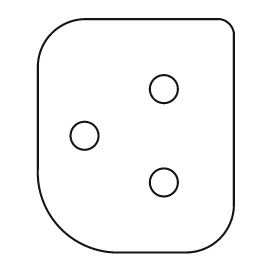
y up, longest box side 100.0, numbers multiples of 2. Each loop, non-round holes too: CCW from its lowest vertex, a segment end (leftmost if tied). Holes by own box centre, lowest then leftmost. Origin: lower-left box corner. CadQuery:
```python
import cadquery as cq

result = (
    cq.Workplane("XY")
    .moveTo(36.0, 0.0)
    .lineTo(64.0, 0.0)
    .threePointArc((78.0, 6.0), (84.0, 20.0))
    .lineTo(84.0, 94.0)
    .threePointArc((82.0, 98.0), (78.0, 100.0))
    .lineTo(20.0, 100.0)
    .threePointArc((6.0, 94.0), (0.0, 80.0))
    .lineTo(0.0, 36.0)
    .threePointArc((10.0, 10.0), (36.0, 0.0))
    .close()
    .moveTo(54.0, 30.0)
    .circle(6.0)
    .moveTo(20.0, 50.0)
    .circle(6.0)
    .moveTo(54.0, 70.0)
    .circle(6.0)
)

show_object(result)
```